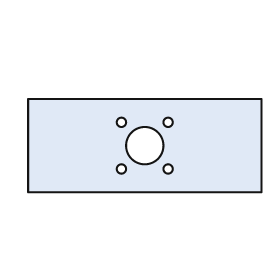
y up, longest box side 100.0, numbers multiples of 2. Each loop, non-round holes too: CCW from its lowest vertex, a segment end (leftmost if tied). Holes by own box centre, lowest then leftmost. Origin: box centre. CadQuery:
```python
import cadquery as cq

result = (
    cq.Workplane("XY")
    .moveTo(-50.0, -20.0)
    .lineTo(50.0, -20.0)
    .lineTo(50.0, 20.0)
    .lineTo(-50.0, 20.0)
    .close()
    .moveTo(-10.0, -10.0)
    .circle(2.0)
    .moveTo(10.0, -10.0)
    .circle(2.0)
    .moveTo(0.0, 0.0)
    .circle(8.0)
    .moveTo(-10.0, 10.0)
    .circle(2.0)
    .moveTo(10.0, 10.0)
    .circle(2.0)
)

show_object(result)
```